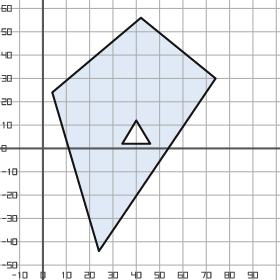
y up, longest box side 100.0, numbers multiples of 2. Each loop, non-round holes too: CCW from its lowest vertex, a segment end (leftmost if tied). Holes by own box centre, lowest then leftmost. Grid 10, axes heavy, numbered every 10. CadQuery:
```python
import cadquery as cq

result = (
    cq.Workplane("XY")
    .moveTo(24.0, -44.0)
    .lineTo(74.0, 30.0)
    .lineTo(42.0, 56.0)
    .lineTo(4.0, 24.0)
    .close()
    .moveTo(34.0, 2.0)
    .lineTo(46.0, 2.0)
    .lineTo(40.0, 12.0)
    .close()
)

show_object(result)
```